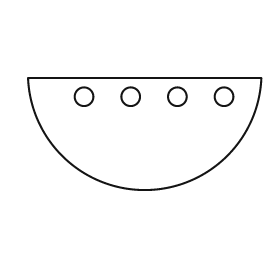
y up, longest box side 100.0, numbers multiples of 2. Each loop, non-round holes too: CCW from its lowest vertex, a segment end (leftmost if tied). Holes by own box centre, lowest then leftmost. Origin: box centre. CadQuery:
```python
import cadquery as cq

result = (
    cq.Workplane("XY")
    .moveTo(-50.0, 24.0)
    .threePointArc((0.0, -24.0), (50.0, 24.0))
    .close()
    .moveTo(-26.0, 16.0)
    .circle(4.0)
    .moveTo(-6.0, 16.0)
    .circle(4.0)
    .moveTo(14.0, 16.0)
    .circle(4.0)
    .moveTo(34.0, 16.0)
    .circle(4.0)
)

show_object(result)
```